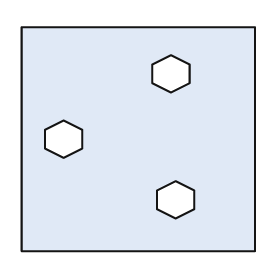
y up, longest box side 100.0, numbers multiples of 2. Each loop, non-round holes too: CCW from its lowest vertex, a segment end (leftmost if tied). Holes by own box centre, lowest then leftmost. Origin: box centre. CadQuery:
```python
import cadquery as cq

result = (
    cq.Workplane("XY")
    .moveTo(-50.0, -48.0)
    .lineTo(50.0, -48.0)
    .lineTo(50.0, 48.0)
    .lineTo(-50.0, 48.0)
    .close()
    .moveTo(16.0, -34.0)
    .lineTo(24.0, -30.0)
    .lineTo(24.0, -22.0)
    .lineTo(16.0, -18.0)
    .lineTo(8.0, -22.0)
    .lineTo(8.0, -30.0)
    .close()
    .moveTo(-32.0, -8.0)
    .lineTo(-24.0, -4.0)
    .lineTo(-24.0, 4.0)
    .lineTo(-32.0, 8.0)
    .lineTo(-40.0, 4.0)
    .lineTo(-40.0, -4.0)
    .close()
    .moveTo(14.0, 20.0)
    .lineTo(22.0, 24.0)
    .lineTo(22.0, 32.0)
    .lineTo(14.0, 36.0)
    .lineTo(6.0, 32.0)
    .lineTo(6.0, 24.0)
    .close()
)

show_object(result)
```